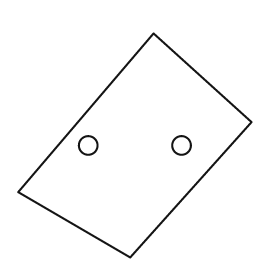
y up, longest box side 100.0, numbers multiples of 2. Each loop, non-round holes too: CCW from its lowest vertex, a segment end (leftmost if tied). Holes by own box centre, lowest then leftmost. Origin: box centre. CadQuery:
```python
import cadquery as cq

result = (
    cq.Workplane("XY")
    .moveTo(-2.0, -48.0)
    .lineTo(50.0, 10.0)
    .lineTo(8.0, 48.0)
    .lineTo(-50.0, -20.0)
    .close()
    .moveTo(-20.0, 0.0)
    .circle(4.0)
    .moveTo(20.0, 0.0)
    .circle(4.0)
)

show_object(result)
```